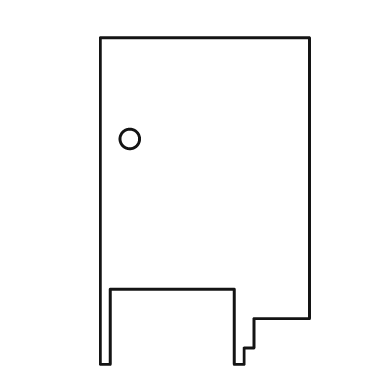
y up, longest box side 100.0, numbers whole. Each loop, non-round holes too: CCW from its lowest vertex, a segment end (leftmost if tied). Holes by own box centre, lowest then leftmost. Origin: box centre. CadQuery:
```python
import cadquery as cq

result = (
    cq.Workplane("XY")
    .moveTo(-32.0, -50.0)
    .lineTo(-29.0, -50.0)
    .lineTo(-29.0, -27.0)
    .lineTo(9.0, -27.0)
    .lineTo(9.0, -50.0)
    .lineTo(12.0, -50.0)
    .lineTo(12.0, -45.0)
    .lineTo(15.0, -45.0)
    .lineTo(15.0, -36.0)
    .lineTo(32.0, -36.0)
    .lineTo(32.0, 50.0)
    .lineTo(-32.0, 50.0)
    .close()
    .moveTo(-23.0, 19.0)
    .circle(3.0)
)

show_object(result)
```